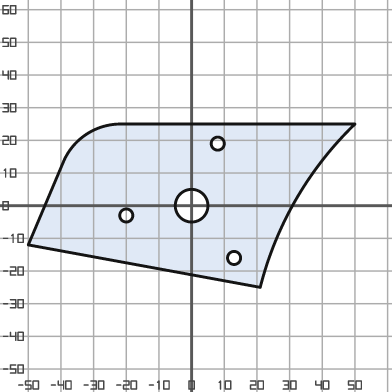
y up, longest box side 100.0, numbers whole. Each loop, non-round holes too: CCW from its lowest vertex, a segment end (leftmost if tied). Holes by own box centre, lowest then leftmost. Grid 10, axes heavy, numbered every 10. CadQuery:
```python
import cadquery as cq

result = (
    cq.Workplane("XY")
    .moveTo(21.0, -25.0)
    .threePointArc((32.0, 2.0), (50.0, 25.0))
    .lineTo(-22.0, 25.0)
    .threePointArc((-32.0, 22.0), (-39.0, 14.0))
    .lineTo(-50.0, -12.0)
    .close()
    .moveTo(13.0, -16.0)
    .circle(2.0)
    .moveTo(-20.0, -3.0)
    .circle(2.0)
    .moveTo(0.0, 0.0)
    .circle(5.0)
    .moveTo(8.0, 19.0)
    .circle(2.0)
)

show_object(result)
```